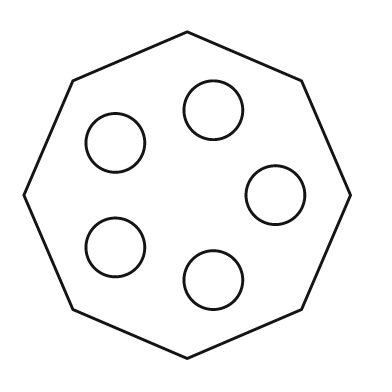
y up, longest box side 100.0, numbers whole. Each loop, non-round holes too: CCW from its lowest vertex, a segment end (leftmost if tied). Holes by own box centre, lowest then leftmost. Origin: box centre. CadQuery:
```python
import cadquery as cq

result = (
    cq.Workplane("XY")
    .moveTo(0.0, -50.0)
    .lineTo(35.0, -35.0)
    .lineTo(50.0, 0.0)
    .lineTo(35.0, 35.0)
    .lineTo(0.0, 50.0)
    .lineTo(-35.0, 35.0)
    .lineTo(-50.0, 0.0)
    .lineTo(-35.0, -35.0)
    .close()
    .moveTo(8.0, -26.0)
    .circle(9.0)
    .moveTo(-22.0, -16.0)
    .circle(9.0)
    .moveTo(27.0, 0.0)
    .circle(9.0)
    .moveTo(-22.0, 16.0)
    .circle(9.0)
    .moveTo(8.0, 26.0)
    .circle(9.0)
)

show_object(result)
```